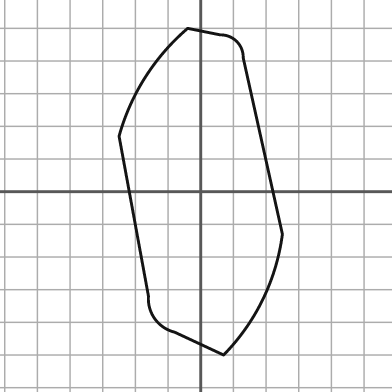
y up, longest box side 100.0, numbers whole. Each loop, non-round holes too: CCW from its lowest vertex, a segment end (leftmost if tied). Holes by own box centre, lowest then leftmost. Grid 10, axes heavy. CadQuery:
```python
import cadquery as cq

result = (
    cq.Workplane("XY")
    .moveTo(7.0, -50.0)
    .threePointArc((19.0, -33.0), (25.0, -13.0))
    .lineTo(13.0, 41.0)
    .threePointArc((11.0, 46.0), (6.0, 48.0))
    .lineTo(-4.0, 50.0)
    .threePointArc((-17.0, 35.0), (-25.0, 17.0))
    .lineTo(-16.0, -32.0)
    .threePointArc((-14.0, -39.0), (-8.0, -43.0))
    .close()
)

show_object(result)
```